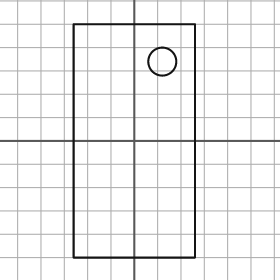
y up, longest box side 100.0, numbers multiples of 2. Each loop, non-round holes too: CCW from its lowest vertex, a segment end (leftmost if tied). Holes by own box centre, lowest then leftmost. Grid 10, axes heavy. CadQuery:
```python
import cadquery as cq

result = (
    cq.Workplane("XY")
    .moveTo(-26.0, -50.0)
    .lineTo(26.0, -50.0)
    .lineTo(26.0, 50.0)
    .lineTo(-26.0, 50.0)
    .close()
    .moveTo(12.0, 34.0)
    .circle(6.0)
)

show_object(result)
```